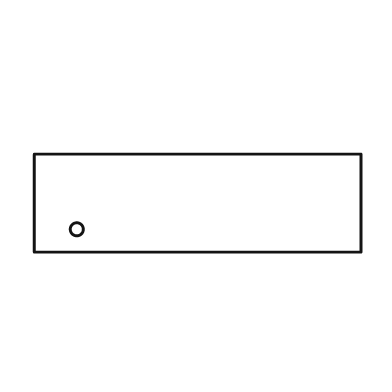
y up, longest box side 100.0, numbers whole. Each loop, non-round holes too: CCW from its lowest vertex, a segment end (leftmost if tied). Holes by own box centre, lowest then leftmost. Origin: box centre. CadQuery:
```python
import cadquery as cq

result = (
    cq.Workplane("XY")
    .moveTo(-50.0, -15.0)
    .lineTo(50.0, -15.0)
    .lineTo(50.0, 15.0)
    .lineTo(-50.0, 15.0)
    .close()
    .moveTo(-37.0, -8.0)
    .circle(2.0)
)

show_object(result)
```